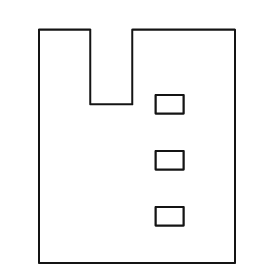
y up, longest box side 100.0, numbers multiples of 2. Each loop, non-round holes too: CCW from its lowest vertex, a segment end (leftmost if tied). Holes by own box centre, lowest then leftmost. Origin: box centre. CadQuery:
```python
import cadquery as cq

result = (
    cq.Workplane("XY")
    .moveTo(-42.0, -50.0)
    .lineTo(42.0, -50.0)
    .lineTo(42.0, 50.0)
    .lineTo(-2.0, 50.0)
    .lineTo(-2.0, 18.0)
    .lineTo(-20.0, 18.0)
    .lineTo(-20.0, 50.0)
    .lineTo(-42.0, 50.0)
    .close()
    .moveTo(8.0, -34.0)
    .lineTo(20.0, -34.0)
    .lineTo(20.0, -26.0)
    .lineTo(8.0, -26.0)
    .close()
    .moveTo(8.0, -10.0)
    .lineTo(20.0, -10.0)
    .lineTo(20.0, -2.0)
    .lineTo(8.0, -2.0)
    .close()
    .moveTo(8.0, 14.0)
    .lineTo(20.0, 14.0)
    .lineTo(20.0, 22.0)
    .lineTo(8.0, 22.0)
    .close()
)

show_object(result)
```